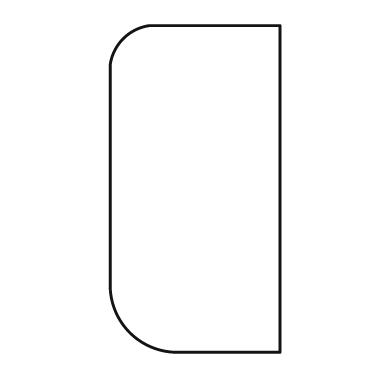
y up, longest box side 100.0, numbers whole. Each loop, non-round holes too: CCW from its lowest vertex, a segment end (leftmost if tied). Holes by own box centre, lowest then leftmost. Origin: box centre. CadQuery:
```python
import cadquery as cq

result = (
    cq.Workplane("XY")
    .moveTo(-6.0, -50.0)
    .lineTo(26.0, -50.0)
    .lineTo(26.0, 50.0)
    .lineTo(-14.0, 50.0)
    .threePointArc((-22.0, 46.0), (-26.0, 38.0))
    .lineTo(-26.0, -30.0)
    .threePointArc((-20.0, -44.0), (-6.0, -50.0))
    .close()
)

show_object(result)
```